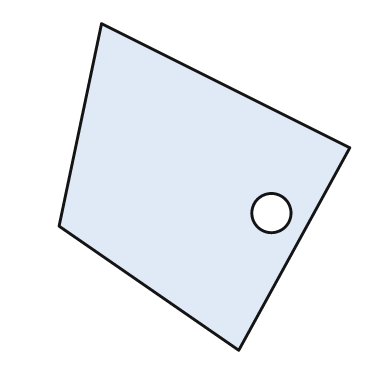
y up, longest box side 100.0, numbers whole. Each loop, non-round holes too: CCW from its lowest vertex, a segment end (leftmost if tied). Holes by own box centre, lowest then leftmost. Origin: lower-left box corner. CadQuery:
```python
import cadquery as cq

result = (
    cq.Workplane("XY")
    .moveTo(55.0, 0.0)
    .lineTo(89.0, 62.0)
    .lineTo(13.0, 100.0)
    .lineTo(0.0, 38.0)
    .close()
    .moveTo(65.0, 42.0)
    .circle(6.0)
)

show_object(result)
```